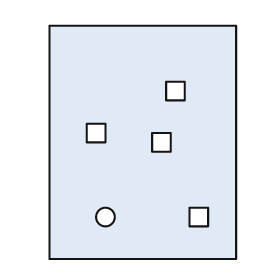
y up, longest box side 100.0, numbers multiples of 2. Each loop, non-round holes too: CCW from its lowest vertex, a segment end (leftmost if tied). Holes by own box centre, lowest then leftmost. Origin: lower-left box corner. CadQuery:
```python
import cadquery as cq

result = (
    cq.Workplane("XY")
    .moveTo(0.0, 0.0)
    .lineTo(80.0, 0.0)
    .lineTo(80.0, 100.0)
    .lineTo(0.0, 100.0)
    .close()
    .moveTo(24.0, 18.0)
    .circle(4.0)
    .moveTo(60.0, 14.0)
    .lineTo(68.0, 14.0)
    .lineTo(68.0, 22.0)
    .lineTo(60.0, 22.0)
    .close()
    .moveTo(44.0, 46.0)
    .lineTo(52.0, 46.0)
    .lineTo(52.0, 54.0)
    .lineTo(44.0, 54.0)
    .close()
    .moveTo(16.0, 50.0)
    .lineTo(24.0, 50.0)
    .lineTo(24.0, 58.0)
    .lineTo(16.0, 58.0)
    .close()
    .moveTo(50.0, 68.0)
    .lineTo(58.0, 68.0)
    .lineTo(58.0, 76.0)
    .lineTo(50.0, 76.0)
    .close()
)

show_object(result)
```